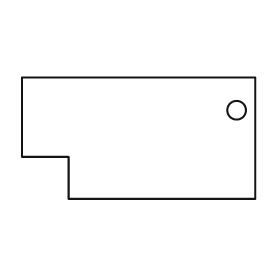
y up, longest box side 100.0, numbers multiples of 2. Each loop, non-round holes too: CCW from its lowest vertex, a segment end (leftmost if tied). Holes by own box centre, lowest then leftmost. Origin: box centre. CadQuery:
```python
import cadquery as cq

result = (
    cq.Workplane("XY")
    .moveTo(-30.0, -26.0)
    .lineTo(50.0, -26.0)
    .lineTo(50.0, 26.0)
    .lineTo(-50.0, 26.0)
    .lineTo(-50.0, -8.0)
    .lineTo(-30.0, -8.0)
    .close()
    .moveTo(42.0, 12.0)
    .circle(4.0)
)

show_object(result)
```